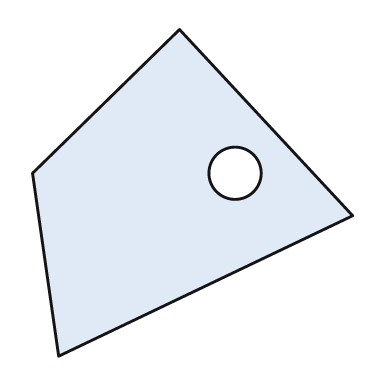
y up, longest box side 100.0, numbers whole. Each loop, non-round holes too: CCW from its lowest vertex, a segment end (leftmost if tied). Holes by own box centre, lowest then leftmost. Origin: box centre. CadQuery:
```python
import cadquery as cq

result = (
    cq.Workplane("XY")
    .moveTo(-41.0, -50.0)
    .lineTo(49.0, -7.0)
    .lineTo(-4.0, 50.0)
    .lineTo(-49.0, 6.0)
    .close()
    .moveTo(13.0, 6.0)
    .circle(8.0)
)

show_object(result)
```